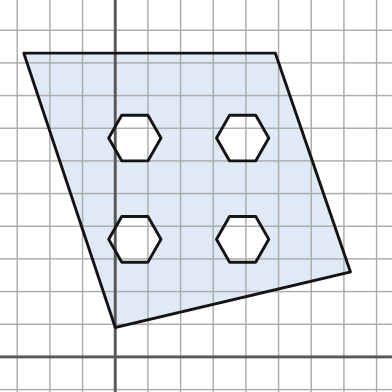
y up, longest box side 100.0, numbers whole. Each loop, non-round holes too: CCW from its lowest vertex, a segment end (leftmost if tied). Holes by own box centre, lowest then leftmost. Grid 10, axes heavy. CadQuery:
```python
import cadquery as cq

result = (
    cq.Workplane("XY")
    .moveTo(0.0, 9.0)
    .lineTo(72.0, 26.0)
    .lineTo(49.0, 93.0)
    .lineTo(-28.0, 93.0)
    .close()
    .moveTo(2.0, 29.0)
    .lineTo(10.0, 29.0)
    .lineTo(14.0, 36.0)
    .lineTo(10.0, 43.0)
    .lineTo(2.0, 43.0)
    .lineTo(-2.0, 36.0)
    .close()
    .moveTo(35.0, 29.0)
    .lineTo(43.0, 29.0)
    .lineTo(47.0, 36.0)
    .lineTo(43.0, 43.0)
    .lineTo(35.0, 43.0)
    .lineTo(31.0, 36.0)
    .close()
    .moveTo(2.0, 60.0)
    .lineTo(10.0, 60.0)
    .lineTo(14.0, 67.0)
    .lineTo(10.0, 74.0)
    .lineTo(2.0, 74.0)
    .lineTo(-2.0, 67.0)
    .close()
    .moveTo(35.0, 60.0)
    .lineTo(43.0, 60.0)
    .lineTo(47.0, 67.0)
    .lineTo(43.0, 74.0)
    .lineTo(35.0, 74.0)
    .lineTo(31.0, 67.0)
    .close()
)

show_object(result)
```